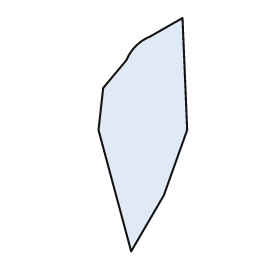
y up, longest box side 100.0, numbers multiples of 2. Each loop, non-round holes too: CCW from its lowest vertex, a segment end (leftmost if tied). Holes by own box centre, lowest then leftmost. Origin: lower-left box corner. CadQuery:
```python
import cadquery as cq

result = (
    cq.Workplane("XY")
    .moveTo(14.0, 0.0)
    .lineTo(28.0, 24.0)
    .lineTo(38.0, 52.0)
    .lineTo(36.0, 100.0)
    .lineTo(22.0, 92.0)
    .threePointArc((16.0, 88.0), (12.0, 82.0))
    .lineTo(2.0, 70.0)
    .lineTo(0.0, 52.0)
    .close()
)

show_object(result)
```